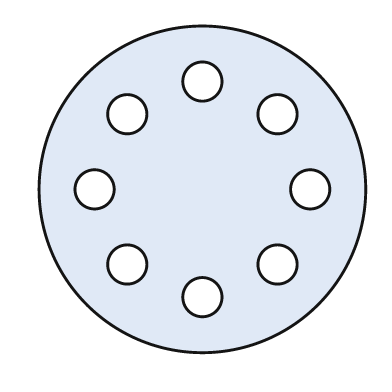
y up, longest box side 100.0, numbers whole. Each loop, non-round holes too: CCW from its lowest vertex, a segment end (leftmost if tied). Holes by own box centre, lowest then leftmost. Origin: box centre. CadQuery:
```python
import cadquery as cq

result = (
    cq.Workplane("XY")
    .moveTo(0.0, 0.0)
    .circle(50.0)
    .moveTo(0.0, -33.0)
    .circle(6.0)
    .moveTo(-23.0, -23.0)
    .circle(6.0)
    .moveTo(23.0, -23.0)
    .circle(6.0)
    .moveTo(-33.0, 0.0)
    .circle(6.0)
    .moveTo(33.0, 0.0)
    .circle(6.0)
    .moveTo(-23.0, 23.0)
    .circle(6.0)
    .moveTo(23.0, 23.0)
    .circle(6.0)
    .moveTo(0.0, 33.0)
    .circle(6.0)
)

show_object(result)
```